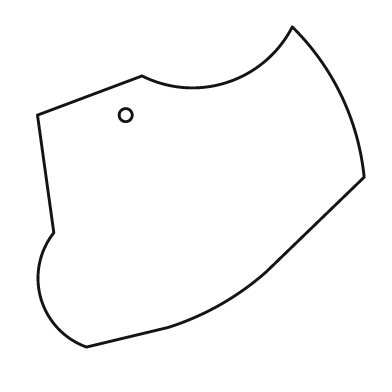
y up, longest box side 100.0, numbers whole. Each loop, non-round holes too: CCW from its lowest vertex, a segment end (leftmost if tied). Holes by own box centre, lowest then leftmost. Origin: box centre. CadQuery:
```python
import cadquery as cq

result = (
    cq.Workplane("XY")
    .moveTo(-35.0, -49.0)
    .lineTo(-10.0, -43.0)
    .threePointArc((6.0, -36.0), (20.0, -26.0))
    .lineTo(50.0, 3.0)
    .threePointArc((43.0, 28.0), (28.0, 49.0))
    .threePointArc((8.0, 32.0), (-18.0, 34.0))
    .lineTo(-50.0, 22.0)
    .lineTo(-45.0, -14.0)
    .threePointArc((-49.0, -34.0), (-35.0, -49.0))
    .close()
    .moveTo(-23.0, 22.0)
    .circle(2.0)
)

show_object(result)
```